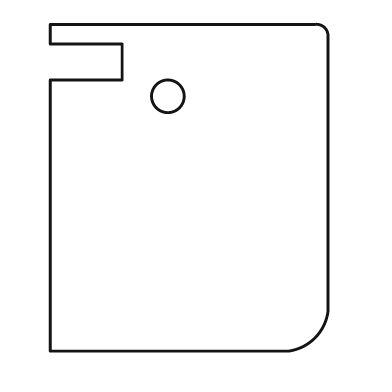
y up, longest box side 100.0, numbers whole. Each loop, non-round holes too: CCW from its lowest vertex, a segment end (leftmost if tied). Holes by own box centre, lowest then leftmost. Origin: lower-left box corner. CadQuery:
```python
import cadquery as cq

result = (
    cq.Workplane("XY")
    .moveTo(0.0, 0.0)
    .lineTo(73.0, 0.0)
    .threePointArc((81.0, 4.0), (85.0, 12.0))
    .lineTo(85.0, 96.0)
    .threePointArc((84.0, 99.0), (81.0, 100.0))
    .lineTo(0.0, 100.0)
    .lineTo(0.0, 94.0)
    .lineTo(22.0, 94.0)
    .lineTo(22.0, 83.0)
    .lineTo(0.0, 83.0)
    .close()
    .moveTo(36.0, 78.0)
    .circle(5.0)
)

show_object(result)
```